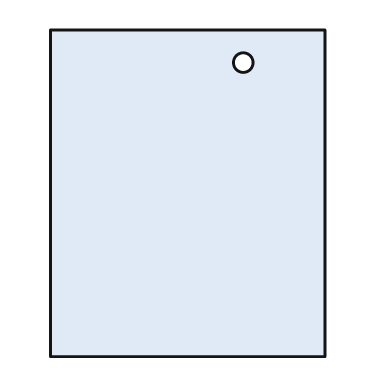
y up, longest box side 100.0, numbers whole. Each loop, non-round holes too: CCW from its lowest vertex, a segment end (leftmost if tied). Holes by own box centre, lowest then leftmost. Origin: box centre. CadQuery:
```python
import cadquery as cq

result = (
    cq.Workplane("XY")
    .moveTo(-42.0, -50.0)
    .lineTo(42.0, -50.0)
    .lineTo(42.0, 50.0)
    .lineTo(-42.0, 50.0)
    .close()
    .moveTo(17.0, 40.0)
    .circle(3.0)
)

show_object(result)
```